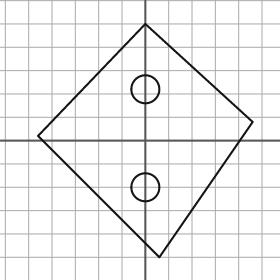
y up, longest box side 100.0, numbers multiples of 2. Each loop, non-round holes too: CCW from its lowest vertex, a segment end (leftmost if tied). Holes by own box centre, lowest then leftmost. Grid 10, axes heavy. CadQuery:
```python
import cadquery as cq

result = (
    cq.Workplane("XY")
    .moveTo(6.0, -50.0)
    .lineTo(46.0, 8.0)
    .lineTo(0.0, 50.0)
    .lineTo(-46.0, 2.0)
    .close()
    .moveTo(0.0, -20.0)
    .circle(6.0)
    .moveTo(0.0, 22.0)
    .circle(6.0)
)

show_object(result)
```